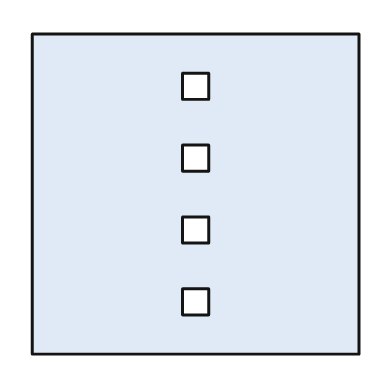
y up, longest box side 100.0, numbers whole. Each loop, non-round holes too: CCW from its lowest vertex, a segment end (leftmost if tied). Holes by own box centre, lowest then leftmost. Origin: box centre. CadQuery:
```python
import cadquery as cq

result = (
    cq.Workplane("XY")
    .moveTo(-50.0, -49.0)
    .lineTo(50.0, -49.0)
    .lineTo(50.0, 49.0)
    .lineTo(-50.0, 49.0)
    .close()
    .moveTo(-4.0, -37.0)
    .lineTo(4.0, -37.0)
    .lineTo(4.0, -29.0)
    .lineTo(-4.0, -29.0)
    .close()
    .moveTo(-4.0, -15.0)
    .lineTo(4.0, -15.0)
    .lineTo(4.0, -7.0)
    .lineTo(-4.0, -7.0)
    .close()
    .moveTo(-4.0, 7.0)
    .lineTo(4.0, 7.0)
    .lineTo(4.0, 15.0)
    .lineTo(-4.0, 15.0)
    .close()
    .moveTo(-4.0, 29.0)
    .lineTo(4.0, 29.0)
    .lineTo(4.0, 37.0)
    .lineTo(-4.0, 37.0)
    .close()
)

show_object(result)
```